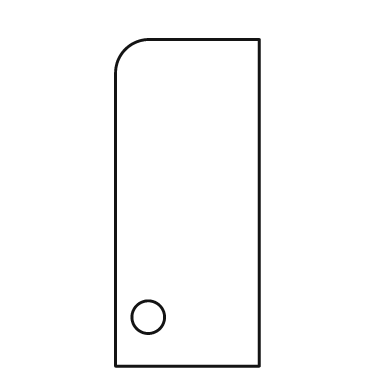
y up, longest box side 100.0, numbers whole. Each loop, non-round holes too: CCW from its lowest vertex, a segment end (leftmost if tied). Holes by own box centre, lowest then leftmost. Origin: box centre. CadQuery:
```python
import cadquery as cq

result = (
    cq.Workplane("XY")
    .moveTo(-22.0, -50.0)
    .lineTo(22.0, -50.0)
    .lineTo(22.0, 50.0)
    .lineTo(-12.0, 50.0)
    .threePointArc((-19.0, 47.0), (-22.0, 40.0))
    .close()
    .moveTo(-12.0, -35.0)
    .circle(5.0)
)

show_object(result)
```